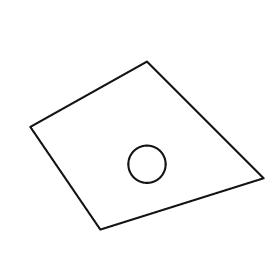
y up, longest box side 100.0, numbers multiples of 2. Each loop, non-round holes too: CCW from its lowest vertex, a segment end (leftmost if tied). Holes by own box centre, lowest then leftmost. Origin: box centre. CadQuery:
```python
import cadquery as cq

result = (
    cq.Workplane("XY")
    .moveTo(-20.0, -36.0)
    .lineTo(50.0, -14.0)
    .lineTo(0.0, 36.0)
    .lineTo(-50.0, 8.0)
    .close()
    .moveTo(0.0, -8.0)
    .circle(8.0)
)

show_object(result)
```